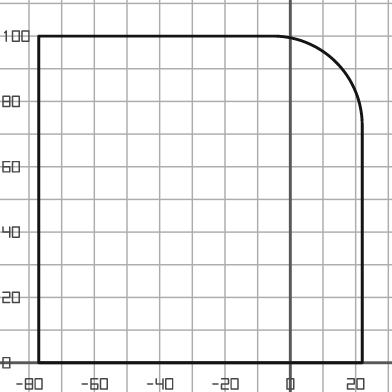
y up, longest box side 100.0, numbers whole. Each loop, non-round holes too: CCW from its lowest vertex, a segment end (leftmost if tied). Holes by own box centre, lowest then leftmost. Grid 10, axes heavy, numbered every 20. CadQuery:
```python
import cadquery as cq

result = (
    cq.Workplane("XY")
    .moveTo(-77.0, 0.0)
    .lineTo(22.0, 0.0)
    .lineTo(22.0, 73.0)
    .threePointArc((14.0, 92.0), (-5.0, 100.0))
    .lineTo(-77.0, 100.0)
    .close()
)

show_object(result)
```